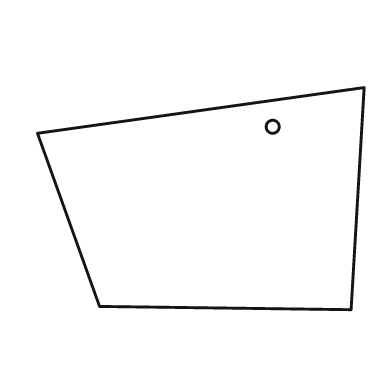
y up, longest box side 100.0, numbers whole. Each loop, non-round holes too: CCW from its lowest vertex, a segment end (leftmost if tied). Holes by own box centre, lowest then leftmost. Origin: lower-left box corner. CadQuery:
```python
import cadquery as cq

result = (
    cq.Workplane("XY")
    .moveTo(96.0, 0.0)
    .lineTo(100.0, 68.0)
    .lineTo(0.0, 54.0)
    .lineTo(19.0, 1.0)
    .close()
    .moveTo(72.0, 56.0)
    .circle(2.0)
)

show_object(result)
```